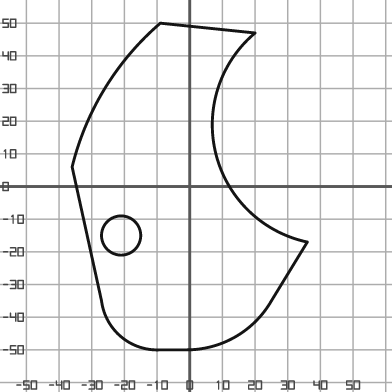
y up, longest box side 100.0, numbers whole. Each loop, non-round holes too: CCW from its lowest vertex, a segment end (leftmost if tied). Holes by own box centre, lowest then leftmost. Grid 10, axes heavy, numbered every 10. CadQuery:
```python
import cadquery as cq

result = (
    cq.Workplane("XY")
    .moveTo(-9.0, -50.0)
    .lineTo(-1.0, -50.0)
    .threePointArc((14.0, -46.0), (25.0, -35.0))
    .lineTo(36.0, -17.0)
    .threePointArc((8.0, 10.0), (20.0, 47.0))
    .lineTo(-9.0, 50.0)
    .threePointArc((-26.0, 30.0), (-36.0, 6.0))
    .lineTo(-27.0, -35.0)
    .threePointArc((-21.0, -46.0), (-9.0, -50.0))
    .close()
    .moveTo(-21.0, -15.0)
    .circle(6.0)
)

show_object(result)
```